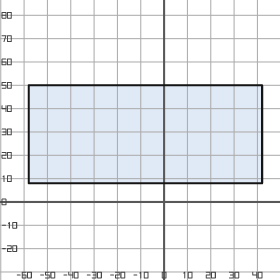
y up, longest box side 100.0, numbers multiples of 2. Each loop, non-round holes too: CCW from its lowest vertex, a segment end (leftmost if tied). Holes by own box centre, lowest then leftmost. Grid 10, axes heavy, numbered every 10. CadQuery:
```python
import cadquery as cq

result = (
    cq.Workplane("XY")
    .moveTo(-58.0, 8.0)
    .lineTo(42.0, 8.0)
    .lineTo(42.0, 50.0)
    .lineTo(-58.0, 50.0)
    .close()
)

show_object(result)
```